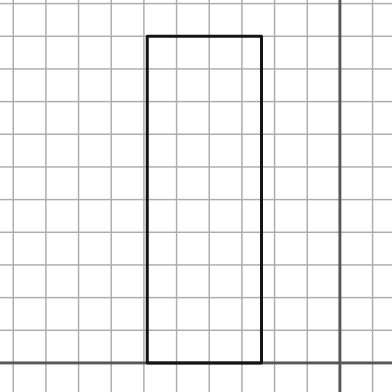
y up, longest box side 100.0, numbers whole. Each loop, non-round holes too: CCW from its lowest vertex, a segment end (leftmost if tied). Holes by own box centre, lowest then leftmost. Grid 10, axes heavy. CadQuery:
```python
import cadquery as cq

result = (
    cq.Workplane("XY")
    .moveTo(-59.0, 0.0)
    .lineTo(-24.0, 0.0)
    .lineTo(-24.0, 100.0)
    .lineTo(-59.0, 100.0)
    .close()
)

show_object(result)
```